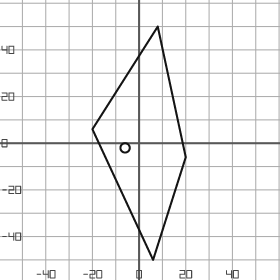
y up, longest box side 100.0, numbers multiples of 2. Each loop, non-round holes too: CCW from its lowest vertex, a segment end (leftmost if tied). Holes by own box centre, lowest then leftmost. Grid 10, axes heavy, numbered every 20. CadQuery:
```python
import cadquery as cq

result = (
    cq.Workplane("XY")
    .moveTo(6.0, -50.0)
    .lineTo(20.0, -6.0)
    .lineTo(8.0, 50.0)
    .lineTo(-20.0, 6.0)
    .close()
    .moveTo(-6.0, -2.0)
    .circle(2.0)
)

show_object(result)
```